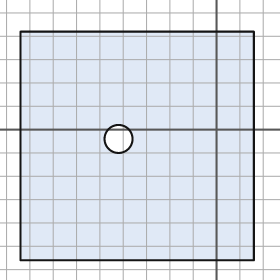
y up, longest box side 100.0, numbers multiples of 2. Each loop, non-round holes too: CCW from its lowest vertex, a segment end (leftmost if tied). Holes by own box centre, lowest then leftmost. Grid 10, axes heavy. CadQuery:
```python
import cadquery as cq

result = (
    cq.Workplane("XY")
    .moveTo(-84.0, -56.0)
    .lineTo(16.0, -56.0)
    .lineTo(16.0, 42.0)
    .lineTo(-84.0, 42.0)
    .close()
    .moveTo(-42.0, -4.0)
    .circle(6.0)
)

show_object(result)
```